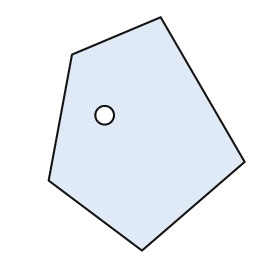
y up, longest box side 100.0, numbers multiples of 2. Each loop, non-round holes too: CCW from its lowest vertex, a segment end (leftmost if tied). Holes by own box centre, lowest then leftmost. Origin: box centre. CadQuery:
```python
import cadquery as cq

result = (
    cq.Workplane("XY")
    .moveTo(-2.0, -50.0)
    .lineTo(42.0, -12.0)
    .lineTo(6.0, 50.0)
    .lineTo(-32.0, 34.0)
    .lineTo(-42.0, -20.0)
    .close()
    .moveTo(-18.0, 8.0)
    .circle(4.0)
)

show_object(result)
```